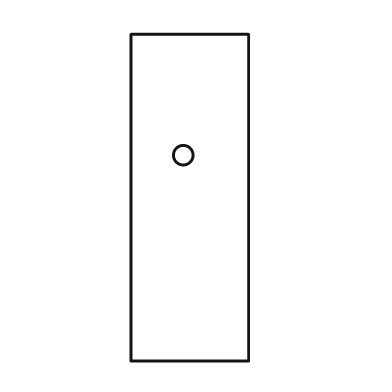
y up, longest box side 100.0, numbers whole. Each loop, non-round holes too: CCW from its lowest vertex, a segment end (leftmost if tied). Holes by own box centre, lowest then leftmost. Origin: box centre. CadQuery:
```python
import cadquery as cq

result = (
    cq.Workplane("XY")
    .moveTo(-18.0, -50.0)
    .lineTo(18.0, -50.0)
    .lineTo(18.0, 50.0)
    .lineTo(-18.0, 50.0)
    .close()
    .moveTo(-2.0, 13.0)
    .circle(3.0)
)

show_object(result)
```